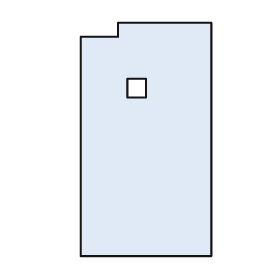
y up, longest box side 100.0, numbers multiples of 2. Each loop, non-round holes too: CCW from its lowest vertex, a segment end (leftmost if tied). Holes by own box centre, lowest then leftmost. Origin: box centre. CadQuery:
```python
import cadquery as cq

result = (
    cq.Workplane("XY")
    .moveTo(-28.0, -50.0)
    .lineTo(28.0, -50.0)
    .lineTo(28.0, 50.0)
    .lineTo(-12.0, 50.0)
    .lineTo(-12.0, 44.0)
    .lineTo(-28.0, 44.0)
    .close()
    .moveTo(-8.0, 18.0)
    .lineTo(0.0, 18.0)
    .lineTo(0.0, 26.0)
    .lineTo(-8.0, 26.0)
    .close()
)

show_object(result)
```